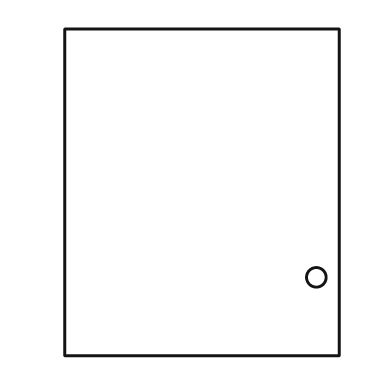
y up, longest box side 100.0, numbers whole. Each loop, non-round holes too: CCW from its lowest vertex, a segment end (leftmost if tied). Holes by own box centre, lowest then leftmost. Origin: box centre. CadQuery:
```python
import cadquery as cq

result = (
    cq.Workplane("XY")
    .moveTo(-42.0, -50.0)
    .lineTo(42.0, -50.0)
    .lineTo(42.0, 50.0)
    .lineTo(-42.0, 50.0)
    .close()
    .moveTo(35.0, -26.0)
    .circle(3.0)
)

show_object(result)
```